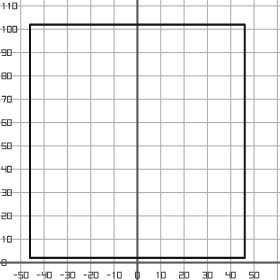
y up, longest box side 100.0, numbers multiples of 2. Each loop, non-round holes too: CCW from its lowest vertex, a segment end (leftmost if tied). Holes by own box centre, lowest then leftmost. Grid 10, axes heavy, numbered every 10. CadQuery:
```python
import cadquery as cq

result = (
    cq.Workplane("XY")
    .moveTo(-46.0, 2.0)
    .lineTo(46.0, 2.0)
    .lineTo(46.0, 102.0)
    .lineTo(-46.0, 102.0)
    .close()
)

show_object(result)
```